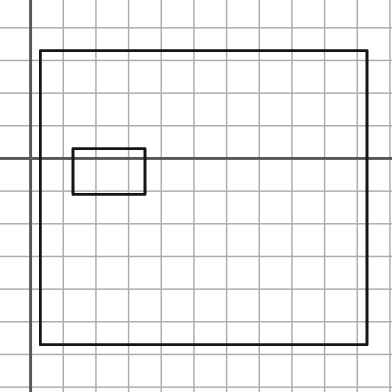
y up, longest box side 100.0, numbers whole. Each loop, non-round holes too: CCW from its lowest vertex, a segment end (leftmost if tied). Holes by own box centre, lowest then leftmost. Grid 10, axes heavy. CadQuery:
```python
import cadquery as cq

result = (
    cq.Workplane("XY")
    .moveTo(3.0, -57.0)
    .lineTo(103.0, -57.0)
    .lineTo(103.0, 33.0)
    .lineTo(3.0, 33.0)
    .close()
    .moveTo(13.0, -11.0)
    .lineTo(35.0, -11.0)
    .lineTo(35.0, 3.0)
    .lineTo(13.0, 3.0)
    .close()
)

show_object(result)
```